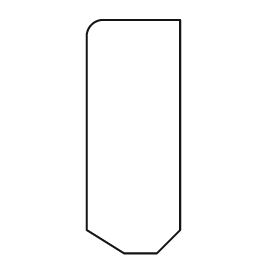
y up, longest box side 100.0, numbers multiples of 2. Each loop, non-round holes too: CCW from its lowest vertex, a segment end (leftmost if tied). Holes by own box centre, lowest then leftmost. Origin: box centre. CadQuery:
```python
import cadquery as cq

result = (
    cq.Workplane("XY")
    .moveTo(-4.0, -50.0)
    .lineTo(10.0, -50.0)
    .lineTo(20.0, -40.0)
    .lineTo(20.0, 50.0)
    .lineTo(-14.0, 50.0)
    .threePointArc((-18.0, 48.0), (-20.0, 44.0))
    .lineTo(-20.0, -40.0)
    .close()
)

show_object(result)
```